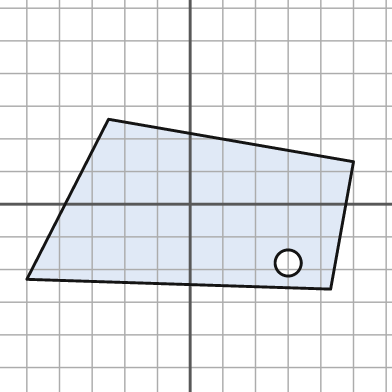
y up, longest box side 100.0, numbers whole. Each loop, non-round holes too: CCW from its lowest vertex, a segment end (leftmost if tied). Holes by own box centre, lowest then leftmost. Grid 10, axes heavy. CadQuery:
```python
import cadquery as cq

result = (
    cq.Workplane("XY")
    .moveTo(43.0, -26.0)
    .lineTo(50.0, 13.0)
    .lineTo(-25.0, 26.0)
    .lineTo(-50.0, -23.0)
    .close()
    .moveTo(30.0, -18.0)
    .circle(4.0)
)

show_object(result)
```